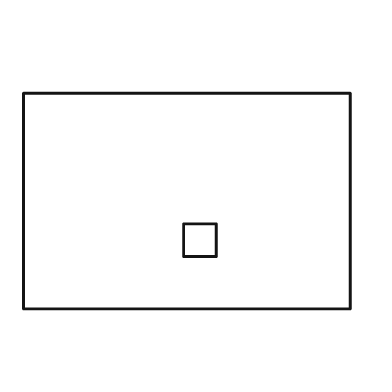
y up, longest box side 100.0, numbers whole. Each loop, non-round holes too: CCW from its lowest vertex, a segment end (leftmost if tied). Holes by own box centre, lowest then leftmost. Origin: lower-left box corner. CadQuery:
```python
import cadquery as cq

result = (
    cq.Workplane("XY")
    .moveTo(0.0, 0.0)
    .lineTo(100.0, 0.0)
    .lineTo(100.0, 66.0)
    .lineTo(0.0, 66.0)
    .close()
    .moveTo(49.0, 16.0)
    .lineTo(59.0, 16.0)
    .lineTo(59.0, 26.0)
    .lineTo(49.0, 26.0)
    .close()
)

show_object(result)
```